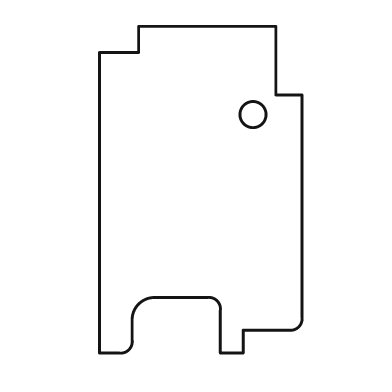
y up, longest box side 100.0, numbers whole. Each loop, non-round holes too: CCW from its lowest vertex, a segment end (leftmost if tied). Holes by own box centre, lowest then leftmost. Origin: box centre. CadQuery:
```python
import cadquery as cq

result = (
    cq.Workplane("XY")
    .moveTo(-31.0, -50.0)
    .lineTo(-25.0, -50.0)
    .threePointArc((-22.0, -49.0), (-21.0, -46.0))
    .lineTo(-21.0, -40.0)
    .threePointArc((-19.0, -35.0), (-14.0, -33.0))
    .lineTo(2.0, -33.0)
    .threePointArc((5.0, -34.0), (6.0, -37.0))
    .lineTo(6.0, -50.0)
    .lineTo(13.0, -50.0)
    .lineTo(13.0, -43.0)
    .lineTo(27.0, -43.0)
    .threePointArc((30.0, -42.0), (31.0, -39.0))
    .lineTo(31.0, 29.0)
    .lineTo(23.0, 29.0)
    .lineTo(23.0, 50.0)
    .lineTo(-19.0, 50.0)
    .lineTo(-19.0, 42.0)
    .lineTo(-31.0, 42.0)
    .close()
    .moveTo(16.0, 23.0)
    .circle(4.0)
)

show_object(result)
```